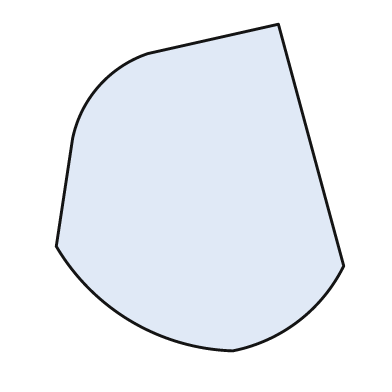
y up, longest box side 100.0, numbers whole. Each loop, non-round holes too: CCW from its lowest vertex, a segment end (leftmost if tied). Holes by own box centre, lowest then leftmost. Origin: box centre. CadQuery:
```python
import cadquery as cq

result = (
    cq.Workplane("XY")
    .moveTo(10.0, -50.0)
    .threePointArc((30.0, -41.0), (44.0, -24.0))
    .lineTo(24.0, 50.0)
    .lineTo(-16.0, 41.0)
    .threePointArc((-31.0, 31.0), (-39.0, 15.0))
    .lineTo(-44.0, -18.0)
    .threePointArc((-21.0, -41.0), (10.0, -50.0))
    .close()
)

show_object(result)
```